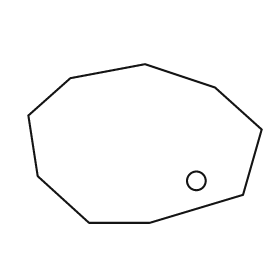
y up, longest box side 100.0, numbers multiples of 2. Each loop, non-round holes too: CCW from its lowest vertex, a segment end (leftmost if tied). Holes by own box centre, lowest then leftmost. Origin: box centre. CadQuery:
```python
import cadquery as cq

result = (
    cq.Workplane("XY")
    .moveTo(-24.0, -34.0)
    .lineTo(2.0, -34.0)
    .lineTo(42.0, -22.0)
    .lineTo(50.0, 6.0)
    .lineTo(30.0, 24.0)
    .lineTo(0.0, 34.0)
    .lineTo(-32.0, 28.0)
    .lineTo(-50.0, 12.0)
    .lineTo(-46.0, -14.0)
    .close()
    .moveTo(22.0, -16.0)
    .circle(4.0)
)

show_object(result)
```